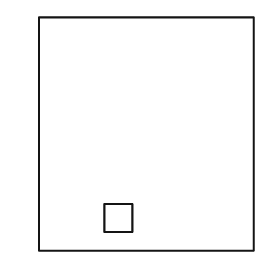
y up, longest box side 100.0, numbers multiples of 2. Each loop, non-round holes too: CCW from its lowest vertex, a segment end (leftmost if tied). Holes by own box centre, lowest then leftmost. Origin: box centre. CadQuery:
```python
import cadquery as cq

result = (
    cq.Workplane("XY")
    .moveTo(-46.0, -50.0)
    .lineTo(46.0, -50.0)
    .lineTo(46.0, 50.0)
    .lineTo(-46.0, 50.0)
    .close()
    .moveTo(-18.0, -42.0)
    .lineTo(-6.0, -42.0)
    .lineTo(-6.0, -30.0)
    .lineTo(-18.0, -30.0)
    .close()
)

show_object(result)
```